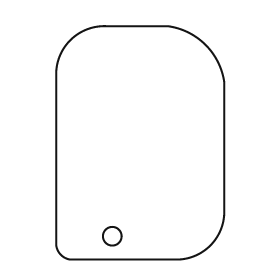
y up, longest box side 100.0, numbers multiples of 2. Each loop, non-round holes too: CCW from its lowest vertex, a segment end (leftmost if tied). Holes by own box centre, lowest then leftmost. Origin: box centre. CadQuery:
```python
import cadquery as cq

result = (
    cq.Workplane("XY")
    .moveTo(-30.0, -50.0)
    .lineTo(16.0, -50.0)
    .threePointArc((30.0, -44.0), (36.0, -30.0))
    .lineTo(36.0, 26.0)
    .threePointArc((28.0, 42.0), (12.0, 50.0))
    .lineTo(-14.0, 50.0)
    .threePointArc((-30.0, 44.0), (-36.0, 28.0))
    .lineTo(-36.0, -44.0)
    .threePointArc((-34.0, -48.0), (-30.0, -50.0))
    .close()
    .moveTo(-12.0, -40.0)
    .circle(4.0)
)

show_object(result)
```